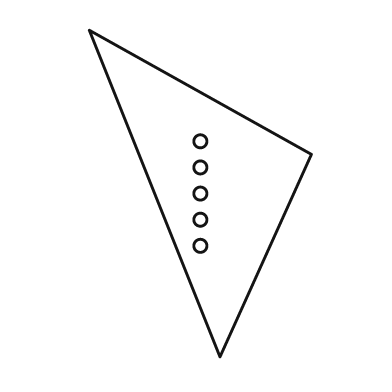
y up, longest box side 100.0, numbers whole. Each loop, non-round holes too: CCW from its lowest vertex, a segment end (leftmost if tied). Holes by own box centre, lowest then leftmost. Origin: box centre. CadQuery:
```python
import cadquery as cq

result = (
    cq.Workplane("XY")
    .moveTo(6.0, -50.0)
    .lineTo(34.0, 12.0)
    .lineTo(-34.0, 50.0)
    .close()
    .moveTo(0.0, -16.0)
    .circle(2.0)
    .moveTo(0.0, -8.0)
    .circle(2.0)
    .moveTo(0.0, 0.0)
    .circle(2.0)
    .moveTo(0.0, 8.0)
    .circle(2.0)
    .moveTo(0.0, 16.0)
    .circle(2.0)
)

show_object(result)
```